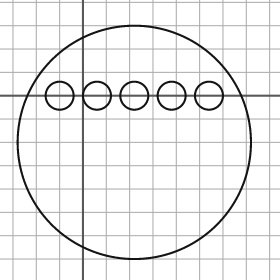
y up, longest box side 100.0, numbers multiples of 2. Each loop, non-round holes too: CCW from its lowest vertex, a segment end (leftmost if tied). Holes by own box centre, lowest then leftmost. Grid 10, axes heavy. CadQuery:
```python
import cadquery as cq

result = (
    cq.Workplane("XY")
    .moveTo(22.0, -20.0)
    .circle(50.0)
    .moveTo(-10.0, 0.0)
    .circle(6.0)
    .moveTo(6.0, 0.0)
    .circle(6.0)
    .moveTo(22.0, 0.0)
    .circle(6.0)
    .moveTo(38.0, 0.0)
    .circle(6.0)
    .moveTo(54.0, 0.0)
    .circle(6.0)
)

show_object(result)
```